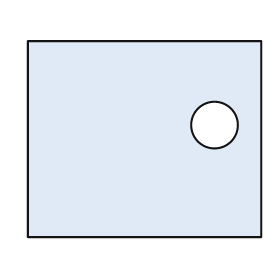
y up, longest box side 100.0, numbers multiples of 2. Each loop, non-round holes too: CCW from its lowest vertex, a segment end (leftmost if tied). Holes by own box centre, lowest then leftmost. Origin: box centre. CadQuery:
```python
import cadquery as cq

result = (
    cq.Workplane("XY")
    .moveTo(-50.0, -42.0)
    .lineTo(50.0, -42.0)
    .lineTo(50.0, 42.0)
    .lineTo(-50.0, 42.0)
    .close()
    .moveTo(30.0, 6.0)
    .circle(10.0)
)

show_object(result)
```